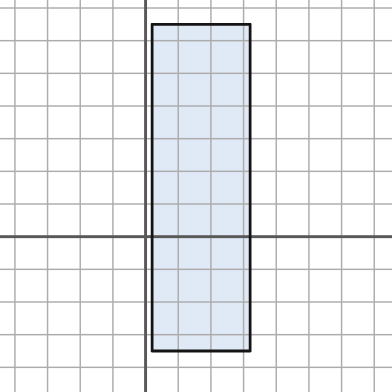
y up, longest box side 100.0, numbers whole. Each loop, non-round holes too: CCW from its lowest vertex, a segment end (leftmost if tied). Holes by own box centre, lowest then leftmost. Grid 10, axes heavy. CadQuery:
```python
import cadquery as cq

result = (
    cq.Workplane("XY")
    .moveTo(2.0, -35.0)
    .lineTo(32.0, -35.0)
    .lineTo(32.0, 65.0)
    .lineTo(2.0, 65.0)
    .close()
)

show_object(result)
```